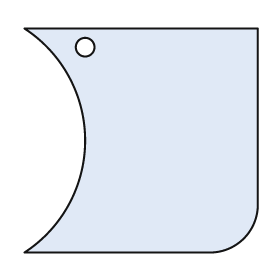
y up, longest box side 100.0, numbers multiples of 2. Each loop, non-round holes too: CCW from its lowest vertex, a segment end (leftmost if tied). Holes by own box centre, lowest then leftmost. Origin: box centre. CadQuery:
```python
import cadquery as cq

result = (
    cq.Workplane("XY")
    .moveTo(-50.0, -48.0)
    .lineTo(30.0, -48.0)
    .threePointArc((44.0, -42.0), (50.0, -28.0))
    .lineTo(50.0, 48.0)
    .lineTo(-50.0, 48.0)
    .threePointArc((-24.0, 0.0), (-50.0, -48.0))
    .close()
    .moveTo(-24.0, 40.0)
    .circle(4.0)
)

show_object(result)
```